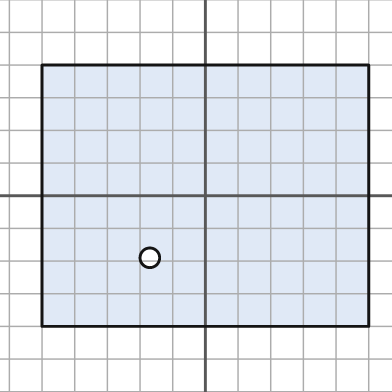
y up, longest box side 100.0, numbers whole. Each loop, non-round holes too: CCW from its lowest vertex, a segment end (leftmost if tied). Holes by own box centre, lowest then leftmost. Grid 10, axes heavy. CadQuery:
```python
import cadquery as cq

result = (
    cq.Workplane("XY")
    .moveTo(-50.0, -40.0)
    .lineTo(50.0, -40.0)
    .lineTo(50.0, 40.0)
    .lineTo(-50.0, 40.0)
    .close()
    .moveTo(-17.0, -19.0)
    .circle(3.0)
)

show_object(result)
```